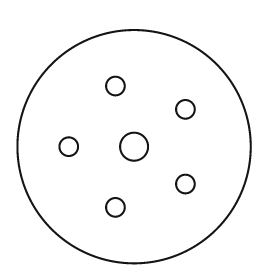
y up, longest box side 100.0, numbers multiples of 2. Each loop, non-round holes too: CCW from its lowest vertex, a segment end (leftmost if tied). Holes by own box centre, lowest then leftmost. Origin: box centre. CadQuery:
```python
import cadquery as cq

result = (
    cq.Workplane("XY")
    .moveTo(0.0, 0.0)
    .circle(50.0)
    .moveTo(-8.0, -26.0)
    .circle(4.0)
    .moveTo(22.0, -16.0)
    .circle(4.0)
    .moveTo(-28.0, 0.0)
    .circle(4.0)
    .moveTo(0.0, 0.0)
    .circle(6.0)
    .moveTo(22.0, 16.0)
    .circle(4.0)
    .moveTo(-8.0, 26.0)
    .circle(4.0)
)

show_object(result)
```